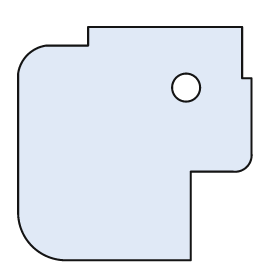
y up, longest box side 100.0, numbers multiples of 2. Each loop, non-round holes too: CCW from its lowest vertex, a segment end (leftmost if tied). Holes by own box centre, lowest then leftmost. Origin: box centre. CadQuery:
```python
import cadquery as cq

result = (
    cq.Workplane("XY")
    .moveTo(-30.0, -50.0)
    .lineTo(24.0, -50.0)
    .lineTo(24.0, -12.0)
    .lineTo(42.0, -12.0)
    .threePointArc((48.0, -10.0), (50.0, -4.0))
    .lineTo(50.0, 28.0)
    .lineTo(46.0, 28.0)
    .lineTo(46.0, 50.0)
    .lineTo(-20.0, 50.0)
    .lineTo(-20.0, 42.0)
    .lineTo(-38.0, 42.0)
    .threePointArc((-46.0, 38.0), (-50.0, 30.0))
    .lineTo(-50.0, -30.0)
    .threePointArc((-44.0, -44.0), (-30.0, -50.0))
    .close()
    .moveTo(22.0, 24.0)
    .circle(6.0)
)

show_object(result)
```